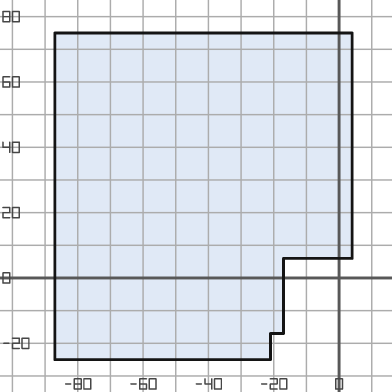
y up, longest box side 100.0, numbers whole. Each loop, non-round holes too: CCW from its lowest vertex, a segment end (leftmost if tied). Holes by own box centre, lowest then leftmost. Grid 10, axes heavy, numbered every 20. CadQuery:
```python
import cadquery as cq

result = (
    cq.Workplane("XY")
    .moveTo(-87.0, -25.0)
    .lineTo(-21.0, -25.0)
    .lineTo(-21.0, -17.0)
    .lineTo(-17.0, -17.0)
    .lineTo(-17.0, 6.0)
    .lineTo(4.0, 6.0)
    .lineTo(4.0, 75.0)
    .lineTo(-87.0, 75.0)
    .close()
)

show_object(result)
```